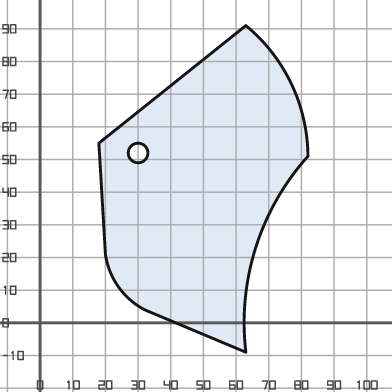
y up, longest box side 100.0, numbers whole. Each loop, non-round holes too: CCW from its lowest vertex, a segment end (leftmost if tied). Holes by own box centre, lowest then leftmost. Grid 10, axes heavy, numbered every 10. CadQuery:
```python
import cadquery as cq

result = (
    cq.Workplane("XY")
    .moveTo(63.0, -9.0)
    .threePointArc((66.0, 23.0), (82.0, 51.0))
    .threePointArc((77.0, 73.0), (63.0, 91.0))
    .lineTo(18.0, 55.0)
    .lineTo(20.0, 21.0)
    .threePointArc((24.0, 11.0), (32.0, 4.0))
    .close()
    .moveTo(30.0, 52.0)
    .circle(3.0)
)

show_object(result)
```